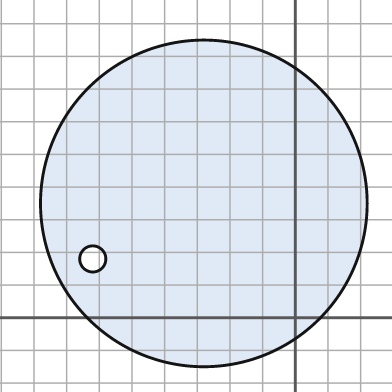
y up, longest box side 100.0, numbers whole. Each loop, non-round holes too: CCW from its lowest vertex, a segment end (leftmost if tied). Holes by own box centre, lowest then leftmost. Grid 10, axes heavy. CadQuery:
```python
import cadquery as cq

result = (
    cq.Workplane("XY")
    .moveTo(-28.0, 35.0)
    .circle(50.0)
    .moveTo(-62.0, 18.0)
    .circle(4.0)
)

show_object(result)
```